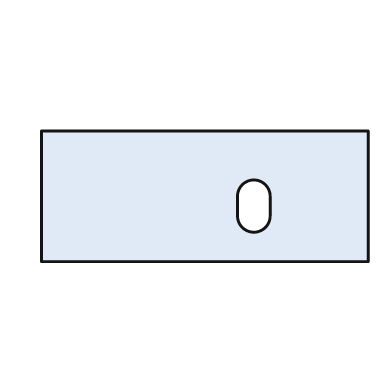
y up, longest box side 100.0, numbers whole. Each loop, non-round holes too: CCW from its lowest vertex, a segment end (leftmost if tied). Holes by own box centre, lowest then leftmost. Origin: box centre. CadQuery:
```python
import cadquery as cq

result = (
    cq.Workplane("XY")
    .moveTo(-50.0, -20.0)
    .lineTo(50.0, -20.0)
    .lineTo(50.0, 20.0)
    .lineTo(-50.0, 20.0)
    .close()
    .moveTo(10.0, -6.0)
    .threePointArc((15.0, -11.0), (20.0, -6.0))
    .lineTo(20.0, 0.0)
    .threePointArc((15.0, 5.0), (10.0, 0.0))
    .close()
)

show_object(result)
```